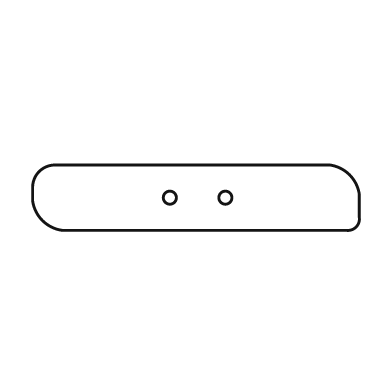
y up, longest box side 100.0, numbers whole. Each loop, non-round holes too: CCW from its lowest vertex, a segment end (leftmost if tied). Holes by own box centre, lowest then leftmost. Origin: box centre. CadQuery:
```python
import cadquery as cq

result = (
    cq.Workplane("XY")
    .moveTo(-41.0, -10.0)
    .lineTo(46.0, -10.0)
    .threePointArc((49.0, -9.0), (50.0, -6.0))
    .lineTo(50.0, 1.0)
    .threePointArc((47.0, 7.0), (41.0, 10.0))
    .lineTo(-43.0, 10.0)
    .threePointArc((-48.0, 8.0), (-50.0, 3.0))
    .lineTo(-50.0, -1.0)
    .threePointArc((-47.0, -7.0), (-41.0, -10.0))
    .close()
    .moveTo(-8.0, 0.0)
    .circle(2.0)
    .moveTo(9.0, 0.0)
    .circle(2.0)
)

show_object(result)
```